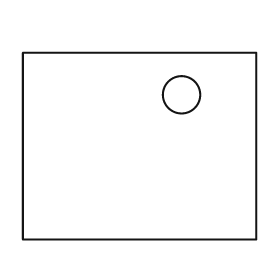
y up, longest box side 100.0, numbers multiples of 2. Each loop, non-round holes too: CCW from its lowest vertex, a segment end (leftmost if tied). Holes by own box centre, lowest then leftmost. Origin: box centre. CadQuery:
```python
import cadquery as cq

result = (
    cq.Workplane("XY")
    .moveTo(-50.0, -40.0)
    .lineTo(50.0, -40.0)
    .lineTo(50.0, 40.0)
    .lineTo(-50.0, 40.0)
    .close()
    .moveTo(18.0, 22.0)
    .circle(8.0)
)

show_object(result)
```